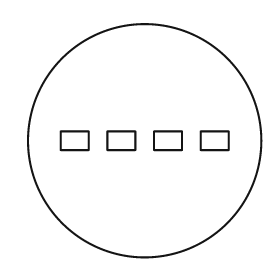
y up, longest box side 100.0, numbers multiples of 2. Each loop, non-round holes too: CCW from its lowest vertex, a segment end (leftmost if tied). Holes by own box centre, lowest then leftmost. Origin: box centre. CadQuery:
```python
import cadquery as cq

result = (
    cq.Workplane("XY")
    .moveTo(0.0, 0.0)
    .circle(50.0)
    .moveTo(-36.0, -4.0)
    .lineTo(-24.0, -4.0)
    .lineTo(-24.0, 4.0)
    .lineTo(-36.0, 4.0)
    .close()
    .moveTo(-16.0, -4.0)
    .lineTo(-4.0, -4.0)
    .lineTo(-4.0, 4.0)
    .lineTo(-16.0, 4.0)
    .close()
    .moveTo(4.0, -4.0)
    .lineTo(16.0, -4.0)
    .lineTo(16.0, 4.0)
    .lineTo(4.0, 4.0)
    .close()
    .moveTo(24.0, -4.0)
    .lineTo(36.0, -4.0)
    .lineTo(36.0, 4.0)
    .lineTo(24.0, 4.0)
    .close()
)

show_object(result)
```